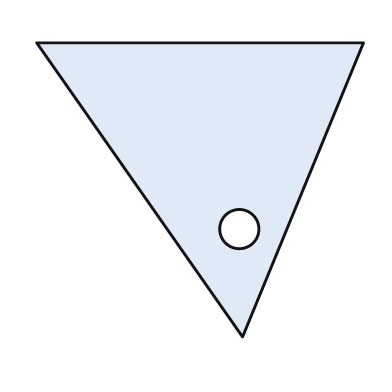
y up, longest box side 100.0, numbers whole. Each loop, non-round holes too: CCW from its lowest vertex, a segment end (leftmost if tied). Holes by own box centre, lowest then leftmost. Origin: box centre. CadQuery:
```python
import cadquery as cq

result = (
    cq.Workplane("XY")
    .moveTo(13.0, -45.0)
    .lineTo(50.0, 45.0)
    .lineTo(-50.0, 45.0)
    .close()
    .moveTo(12.0, -12.0)
    .circle(6.0)
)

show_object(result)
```